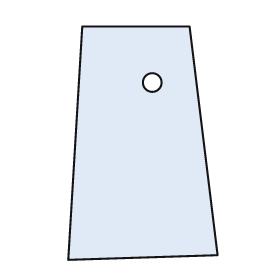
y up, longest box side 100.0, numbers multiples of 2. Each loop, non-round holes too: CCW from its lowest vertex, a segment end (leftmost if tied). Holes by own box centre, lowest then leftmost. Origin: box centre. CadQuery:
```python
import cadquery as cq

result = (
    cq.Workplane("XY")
    .moveTo(-32.0, -50.0)
    .lineTo(32.0, -48.0)
    .lineTo(20.0, 50.0)
    .lineTo(-26.0, 50.0)
    .close()
    .moveTo(4.0, 26.0)
    .circle(4.0)
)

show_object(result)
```